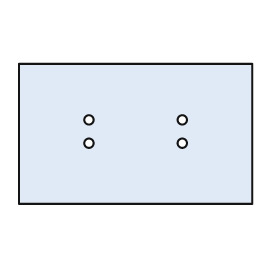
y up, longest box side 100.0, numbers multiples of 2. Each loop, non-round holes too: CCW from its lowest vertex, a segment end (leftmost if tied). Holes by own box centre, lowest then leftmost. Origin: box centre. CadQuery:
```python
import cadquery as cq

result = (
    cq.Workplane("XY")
    .moveTo(-50.0, -30.0)
    .lineTo(50.0, -30.0)
    .lineTo(50.0, 30.0)
    .lineTo(-50.0, 30.0)
    .close()
    .moveTo(-20.0, -4.0)
    .circle(2.0)
    .moveTo(20.0, -4.0)
    .circle(2.0)
    .moveTo(-20.0, 6.0)
    .circle(2.0)
    .moveTo(20.0, 6.0)
    .circle(2.0)
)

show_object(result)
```